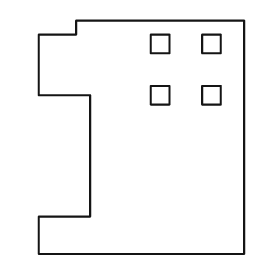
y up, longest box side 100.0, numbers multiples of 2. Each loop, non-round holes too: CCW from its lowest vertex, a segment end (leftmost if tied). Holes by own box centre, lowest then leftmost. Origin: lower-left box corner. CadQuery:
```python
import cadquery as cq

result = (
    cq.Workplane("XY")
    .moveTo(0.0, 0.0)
    .lineTo(88.0, 0.0)
    .lineTo(88.0, 100.0)
    .lineTo(16.0, 100.0)
    .lineTo(16.0, 94.0)
    .lineTo(0.0, 94.0)
    .lineTo(0.0, 68.0)
    .lineTo(22.0, 68.0)
    .lineTo(22.0, 16.0)
    .lineTo(0.0, 16.0)
    .close()
    .moveTo(48.0, 64.0)
    .lineTo(56.0, 64.0)
    .lineTo(56.0, 72.0)
    .lineTo(48.0, 72.0)
    .close()
    .moveTo(70.0, 64.0)
    .lineTo(78.0, 64.0)
    .lineTo(78.0, 72.0)
    .lineTo(70.0, 72.0)
    .close()
    .moveTo(48.0, 86.0)
    .lineTo(56.0, 86.0)
    .lineTo(56.0, 94.0)
    .lineTo(48.0, 94.0)
    .close()
    .moveTo(70.0, 86.0)
    .lineTo(78.0, 86.0)
    .lineTo(78.0, 94.0)
    .lineTo(70.0, 94.0)
    .close()
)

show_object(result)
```